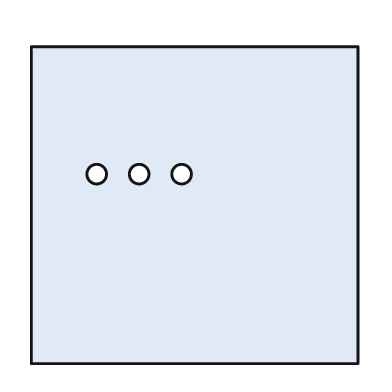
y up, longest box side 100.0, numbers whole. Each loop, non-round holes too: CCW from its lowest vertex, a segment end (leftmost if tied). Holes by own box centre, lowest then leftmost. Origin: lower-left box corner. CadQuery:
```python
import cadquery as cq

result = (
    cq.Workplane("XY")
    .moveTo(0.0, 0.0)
    .lineTo(100.0, 0.0)
    .lineTo(100.0, 97.0)
    .lineTo(0.0, 97.0)
    .close()
    .moveTo(20.0, 58.0)
    .circle(3.0)
    .moveTo(33.0, 58.0)
    .circle(3.0)
    .moveTo(46.0, 58.0)
    .circle(3.0)
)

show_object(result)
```